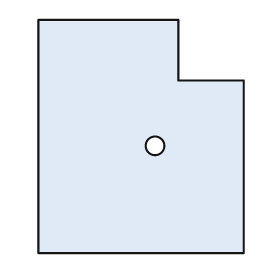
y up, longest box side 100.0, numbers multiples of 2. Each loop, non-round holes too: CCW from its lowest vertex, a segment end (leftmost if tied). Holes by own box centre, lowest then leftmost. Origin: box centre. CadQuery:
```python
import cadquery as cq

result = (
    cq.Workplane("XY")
    .moveTo(-44.0, -50.0)
    .lineTo(44.0, -50.0)
    .lineTo(44.0, 24.0)
    .lineTo(16.0, 24.0)
    .lineTo(16.0, 50.0)
    .lineTo(-44.0, 50.0)
    .close()
    .moveTo(6.0, -4.0)
    .circle(4.0)
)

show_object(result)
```